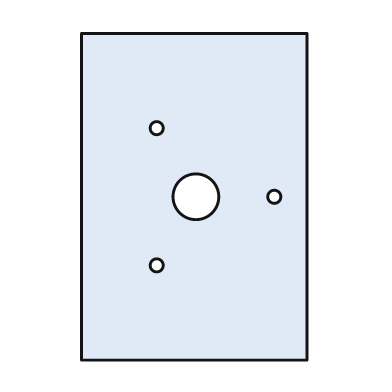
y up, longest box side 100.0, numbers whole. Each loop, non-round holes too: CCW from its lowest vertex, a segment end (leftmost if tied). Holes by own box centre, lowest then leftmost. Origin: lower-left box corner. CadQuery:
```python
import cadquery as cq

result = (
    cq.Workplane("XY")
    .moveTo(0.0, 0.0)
    .lineTo(69.0, 0.0)
    .lineTo(69.0, 100.0)
    .lineTo(0.0, 100.0)
    .close()
    .moveTo(23.0, 29.0)
    .circle(2.0)
    .moveTo(35.0, 50.0)
    .circle(7.0)
    .moveTo(59.0, 50.0)
    .circle(2.0)
    .moveTo(23.0, 71.0)
    .circle(2.0)
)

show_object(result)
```